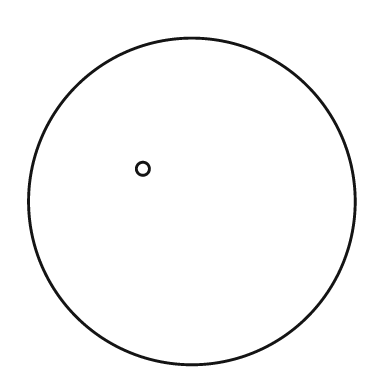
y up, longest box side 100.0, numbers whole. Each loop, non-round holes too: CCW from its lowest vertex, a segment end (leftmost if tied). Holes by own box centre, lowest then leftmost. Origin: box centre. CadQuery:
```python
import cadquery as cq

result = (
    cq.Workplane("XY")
    .moveTo(0.0, 0.0)
    .circle(50.0)
    .moveTo(-15.0, 10.0)
    .circle(2.0)
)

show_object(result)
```